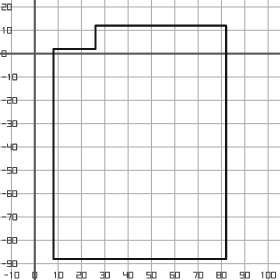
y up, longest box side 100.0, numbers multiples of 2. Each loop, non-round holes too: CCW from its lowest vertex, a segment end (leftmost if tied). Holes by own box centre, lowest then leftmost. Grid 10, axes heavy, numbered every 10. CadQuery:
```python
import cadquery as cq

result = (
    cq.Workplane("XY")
    .moveTo(8.0, -88.0)
    .lineTo(82.0, -88.0)
    .lineTo(82.0, 12.0)
    .lineTo(26.0, 12.0)
    .lineTo(26.0, 2.0)
    .lineTo(8.0, 2.0)
    .close()
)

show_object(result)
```